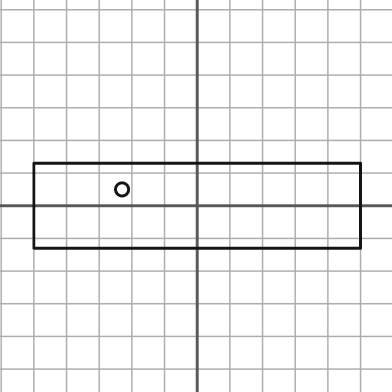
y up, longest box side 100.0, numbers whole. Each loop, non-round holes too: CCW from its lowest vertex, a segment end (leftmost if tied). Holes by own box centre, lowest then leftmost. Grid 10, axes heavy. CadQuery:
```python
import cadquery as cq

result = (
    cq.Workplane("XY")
    .moveTo(-50.0, -13.0)
    .lineTo(50.0, -13.0)
    .lineTo(50.0, 13.0)
    .lineTo(-50.0, 13.0)
    .close()
    .moveTo(-23.0, 5.0)
    .circle(2.0)
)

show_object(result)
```